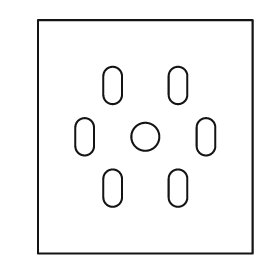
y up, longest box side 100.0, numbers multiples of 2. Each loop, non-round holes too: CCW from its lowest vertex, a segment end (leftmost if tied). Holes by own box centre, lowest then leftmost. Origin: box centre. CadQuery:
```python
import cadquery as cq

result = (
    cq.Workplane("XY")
    .moveTo(-46.0, -50.0)
    .lineTo(46.0, -50.0)
    .lineTo(46.0, 50.0)
    .lineTo(-46.0, 50.0)
    .close()
    .moveTo(-18.0, -26.0)
    .threePointArc((-14.0, -30.0), (-10.0, -26.0))
    .lineTo(-10.0, -18.0)
    .threePointArc((-14.0, -14.0), (-18.0, -18.0))
    .close()
    .moveTo(10.0, -26.0)
    .threePointArc((14.0, -30.0), (18.0, -26.0))
    .lineTo(18.0, -18.0)
    .threePointArc((14.0, -14.0), (10.0, -18.0))
    .close()
    .moveTo(-30.0, -4.0)
    .threePointArc((-26.0, -8.0), (-22.0, -4.0))
    .lineTo(-22.0, 4.0)
    .threePointArc((-26.0, 8.0), (-30.0, 4.0))
    .close()
    .moveTo(0.0, 0.0)
    .circle(6.0)
    .moveTo(22.0, -4.0)
    .threePointArc((26.0, -8.0), (30.0, -4.0))
    .lineTo(30.0, 4.0)
    .threePointArc((26.0, 8.0), (22.0, 4.0))
    .close()
    .moveTo(-18.0, 18.0)
    .threePointArc((-14.0, 14.0), (-10.0, 18.0))
    .lineTo(-10.0, 26.0)
    .threePointArc((-14.0, 30.0), (-18.0, 26.0))
    .close()
    .moveTo(10.0, 18.0)
    .threePointArc((14.0, 14.0), (18.0, 18.0))
    .lineTo(18.0, 26.0)
    .threePointArc((14.0, 30.0), (10.0, 26.0))
    .close()
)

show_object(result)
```